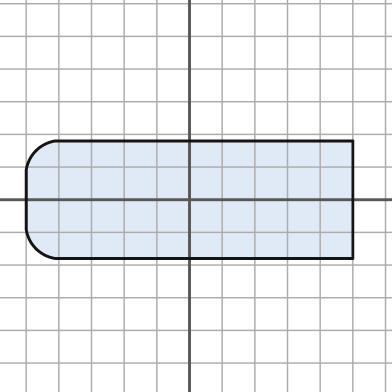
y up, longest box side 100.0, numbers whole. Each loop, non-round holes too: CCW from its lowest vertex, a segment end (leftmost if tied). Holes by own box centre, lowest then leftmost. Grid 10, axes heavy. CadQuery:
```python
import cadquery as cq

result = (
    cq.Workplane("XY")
    .moveTo(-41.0, -18.0)
    .lineTo(50.0, -18.0)
    .lineTo(50.0, 18.0)
    .lineTo(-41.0, 18.0)
    .threePointArc((-47.0, 15.0), (-50.0, 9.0))
    .lineTo(-50.0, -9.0)
    .threePointArc((-47.0, -15.0), (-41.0, -18.0))
    .close()
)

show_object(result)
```